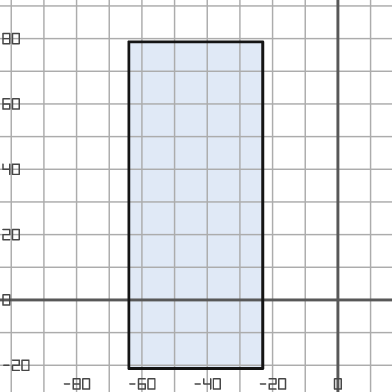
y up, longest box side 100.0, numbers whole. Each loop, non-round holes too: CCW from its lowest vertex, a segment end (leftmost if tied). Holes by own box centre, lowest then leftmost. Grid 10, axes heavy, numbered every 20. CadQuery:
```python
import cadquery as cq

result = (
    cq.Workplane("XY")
    .moveTo(-64.0, -21.0)
    .lineTo(-23.0, -21.0)
    .lineTo(-23.0, 79.0)
    .lineTo(-64.0, 79.0)
    .close()
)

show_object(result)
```